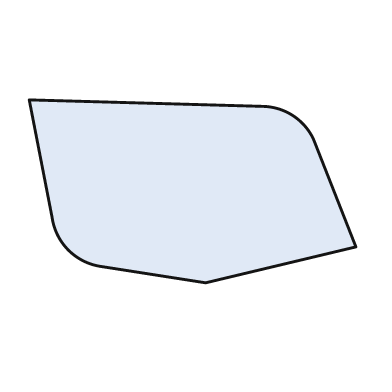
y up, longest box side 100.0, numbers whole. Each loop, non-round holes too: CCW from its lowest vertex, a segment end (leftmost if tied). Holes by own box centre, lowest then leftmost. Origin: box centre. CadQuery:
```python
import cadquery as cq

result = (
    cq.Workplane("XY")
    .moveTo(4.0, -28.0)
    .lineTo(50.0, -17.0)
    .lineTo(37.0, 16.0)
    .threePointArc((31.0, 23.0), (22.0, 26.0))
    .lineTo(-50.0, 28.0)
    .lineTo(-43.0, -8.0)
    .threePointArc((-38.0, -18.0), (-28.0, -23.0))
    .close()
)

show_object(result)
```